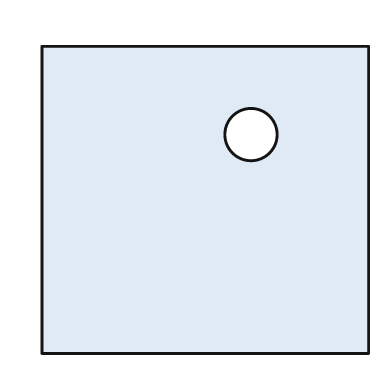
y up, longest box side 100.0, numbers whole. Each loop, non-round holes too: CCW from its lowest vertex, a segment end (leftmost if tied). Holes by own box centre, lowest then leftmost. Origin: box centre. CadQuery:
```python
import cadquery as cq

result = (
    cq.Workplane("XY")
    .moveTo(-50.0, -47.0)
    .lineTo(50.0, -47.0)
    .lineTo(50.0, 47.0)
    .lineTo(-50.0, 47.0)
    .close()
    .moveTo(14.0, 20.0)
    .circle(8.0)
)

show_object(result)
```